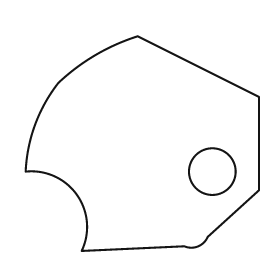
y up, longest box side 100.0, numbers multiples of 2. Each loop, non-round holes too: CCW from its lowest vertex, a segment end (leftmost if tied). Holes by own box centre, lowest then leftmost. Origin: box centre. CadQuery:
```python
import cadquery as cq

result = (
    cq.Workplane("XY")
    .moveTo(-26.0, -46.0)
    .lineTo(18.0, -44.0)
    .threePointArc((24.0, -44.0), (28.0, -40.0))
    .lineTo(50.0, -20.0)
    .lineTo(50.0, 20.0)
    .lineTo(-2.0, 46.0)
    .threePointArc((-20.0, 38.0), (-36.0, 26.0))
    .threePointArc((-46.0, 8.0), (-50.0, -12.0))
    .threePointArc((-28.0, -22.0), (-26.0, -46.0))
    .close()
    .moveTo(30.0, -12.0)
    .circle(10.0)
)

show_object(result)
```